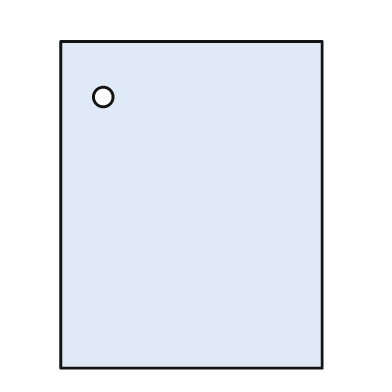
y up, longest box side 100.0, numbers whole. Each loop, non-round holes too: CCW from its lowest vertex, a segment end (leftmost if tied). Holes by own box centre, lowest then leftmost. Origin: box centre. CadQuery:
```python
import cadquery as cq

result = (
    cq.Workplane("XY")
    .moveTo(-40.0, -50.0)
    .lineTo(40.0, -50.0)
    .lineTo(40.0, 50.0)
    .lineTo(-40.0, 50.0)
    .close()
    .moveTo(-27.0, 33.0)
    .circle(3.0)
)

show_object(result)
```